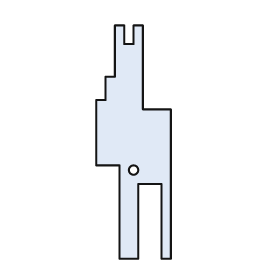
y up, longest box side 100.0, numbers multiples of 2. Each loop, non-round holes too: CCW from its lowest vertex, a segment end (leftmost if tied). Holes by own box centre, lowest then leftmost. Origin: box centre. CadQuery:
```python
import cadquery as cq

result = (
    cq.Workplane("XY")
    .moveTo(-6.0, -50.0)
    .lineTo(2.0, -50.0)
    .lineTo(2.0, -18.0)
    .lineTo(12.0, -18.0)
    .lineTo(12.0, -50.0)
    .lineTo(16.0, -50.0)
    .lineTo(16.0, 14.0)
    .lineTo(4.0, 14.0)
    .lineTo(4.0, 50.0)
    .lineTo(0.0, 50.0)
    .lineTo(0.0, 42.0)
    .lineTo(-4.0, 42.0)
    .lineTo(-4.0, 50.0)
    .lineTo(-8.0, 50.0)
    .lineTo(-8.0, 28.0)
    .lineTo(-12.0, 28.0)
    .lineTo(-12.0, 18.0)
    .lineTo(-16.0, 18.0)
    .lineTo(-16.0, -10.0)
    .lineTo(-6.0, -10.0)
    .close()
    .moveTo(0.0, -12.0)
    .circle(2.0)
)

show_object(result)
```